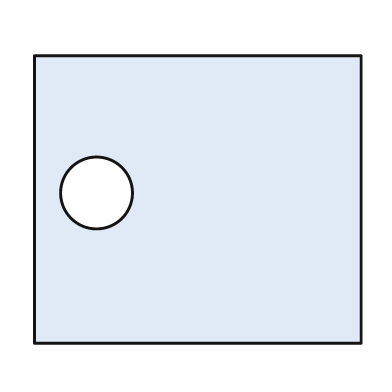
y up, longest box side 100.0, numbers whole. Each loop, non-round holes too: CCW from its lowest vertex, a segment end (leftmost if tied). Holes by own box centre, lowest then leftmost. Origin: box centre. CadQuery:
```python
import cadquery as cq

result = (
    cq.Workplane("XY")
    .moveTo(-50.0, -44.0)
    .lineTo(50.0, -44.0)
    .lineTo(50.0, 44.0)
    .lineTo(-50.0, 44.0)
    .close()
    .moveTo(-31.0, 2.0)
    .circle(11.0)
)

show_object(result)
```